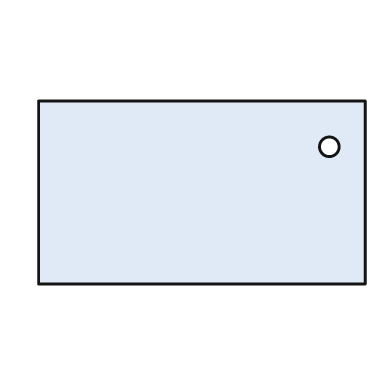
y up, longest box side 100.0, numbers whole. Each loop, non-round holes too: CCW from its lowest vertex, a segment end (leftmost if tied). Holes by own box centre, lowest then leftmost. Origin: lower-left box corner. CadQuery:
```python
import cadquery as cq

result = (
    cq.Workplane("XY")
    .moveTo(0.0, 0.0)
    .lineTo(100.0, 0.0)
    .lineTo(100.0, 56.0)
    .lineTo(0.0, 56.0)
    .close()
    .moveTo(89.0, 42.0)
    .circle(3.0)
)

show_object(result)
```